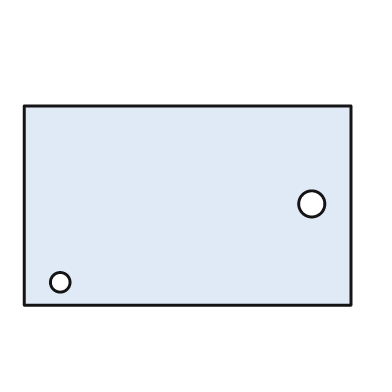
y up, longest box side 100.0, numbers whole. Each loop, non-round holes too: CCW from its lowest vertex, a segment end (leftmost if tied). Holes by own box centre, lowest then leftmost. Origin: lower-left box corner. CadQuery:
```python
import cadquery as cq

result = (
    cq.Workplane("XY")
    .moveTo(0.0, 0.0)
    .lineTo(100.0, 0.0)
    .lineTo(100.0, 61.0)
    .lineTo(0.0, 61.0)
    .close()
    .moveTo(11.0, 7.0)
    .circle(3.0)
    .moveTo(88.0, 31.0)
    .circle(4.0)
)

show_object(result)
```